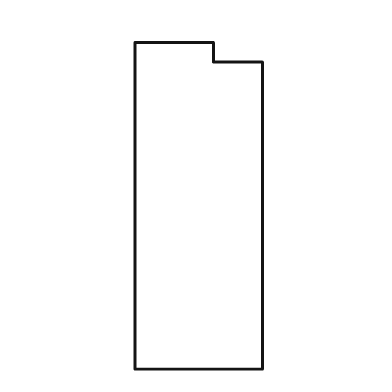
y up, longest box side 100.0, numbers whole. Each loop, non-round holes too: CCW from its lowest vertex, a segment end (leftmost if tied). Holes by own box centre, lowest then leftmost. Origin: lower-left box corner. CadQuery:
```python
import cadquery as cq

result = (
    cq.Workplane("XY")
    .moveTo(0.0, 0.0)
    .lineTo(39.0, 0.0)
    .lineTo(39.0, 94.0)
    .lineTo(24.0, 94.0)
    .lineTo(24.0, 100.0)
    .lineTo(0.0, 100.0)
    .close()
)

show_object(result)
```